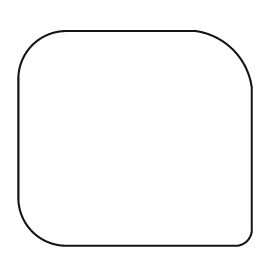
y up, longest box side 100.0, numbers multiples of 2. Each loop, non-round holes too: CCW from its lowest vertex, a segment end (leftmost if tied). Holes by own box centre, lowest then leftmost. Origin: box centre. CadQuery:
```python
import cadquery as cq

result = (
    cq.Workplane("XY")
    .moveTo(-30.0, -46.0)
    .lineTo(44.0, -46.0)
    .threePointArc((48.0, -44.0), (50.0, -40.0))
    .lineTo(50.0, 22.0)
    .threePointArc((42.0, 38.0), (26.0, 46.0))
    .lineTo(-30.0, 46.0)
    .threePointArc((-44.0, 40.0), (-50.0, 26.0))
    .lineTo(-50.0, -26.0)
    .threePointArc((-44.0, -40.0), (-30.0, -46.0))
    .close()
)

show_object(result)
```